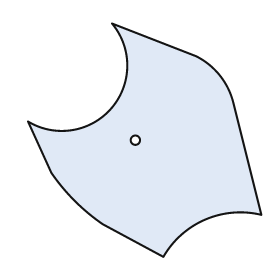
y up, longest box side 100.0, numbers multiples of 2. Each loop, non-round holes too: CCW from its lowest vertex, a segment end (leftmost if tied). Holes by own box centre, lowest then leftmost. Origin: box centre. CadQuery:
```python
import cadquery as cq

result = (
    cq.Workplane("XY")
    .moveTo(8.0, -50.0)
    .threePointArc((26.0, -34.0), (50.0, -32.0))
    .lineTo(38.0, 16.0)
    .threePointArc((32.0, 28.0), (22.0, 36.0))
    .lineTo(-14.0, 50.0)
    .threePointArc((-14.0, 14.0), (-50.0, 8.0))
    .lineTo(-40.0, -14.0)
    .threePointArc((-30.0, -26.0), (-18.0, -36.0))
    .close()
    .moveTo(-4.0, 0.0)
    .circle(2.0)
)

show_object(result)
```